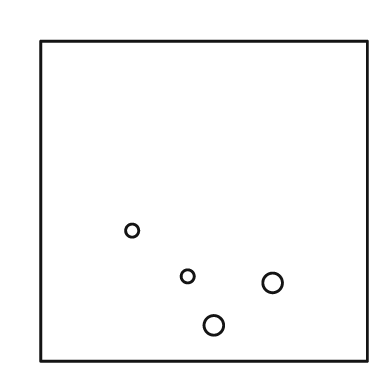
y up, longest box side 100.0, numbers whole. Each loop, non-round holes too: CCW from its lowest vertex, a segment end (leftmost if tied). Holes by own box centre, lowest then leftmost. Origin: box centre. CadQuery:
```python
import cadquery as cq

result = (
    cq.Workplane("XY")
    .moveTo(-50.0, -49.0)
    .lineTo(50.0, -49.0)
    .lineTo(50.0, 49.0)
    .lineTo(-50.0, 49.0)
    .close()
    .moveTo(3.0, -38.0)
    .circle(3.0)
    .moveTo(21.0, -25.0)
    .circle(3.0)
    .moveTo(-5.0, -23.0)
    .circle(2.0)
    .moveTo(-22.0, -9.0)
    .circle(2.0)
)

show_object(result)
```